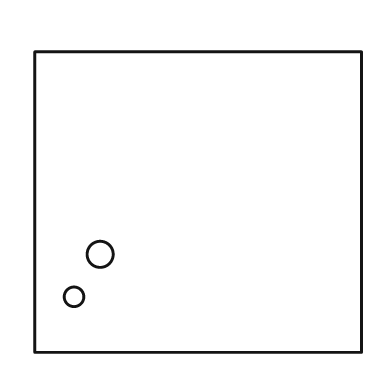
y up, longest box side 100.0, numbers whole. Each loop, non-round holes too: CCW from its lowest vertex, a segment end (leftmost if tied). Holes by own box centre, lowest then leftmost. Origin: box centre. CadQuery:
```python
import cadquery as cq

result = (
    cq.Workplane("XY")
    .moveTo(-50.0, -46.0)
    .lineTo(50.0, -46.0)
    .lineTo(50.0, 46.0)
    .lineTo(-50.0, 46.0)
    .close()
    .moveTo(-38.0, -29.0)
    .circle(3.0)
    .moveTo(-30.0, -16.0)
    .circle(4.0)
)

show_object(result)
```